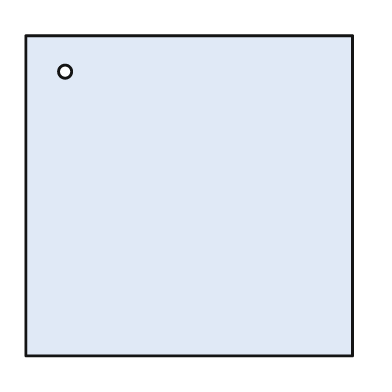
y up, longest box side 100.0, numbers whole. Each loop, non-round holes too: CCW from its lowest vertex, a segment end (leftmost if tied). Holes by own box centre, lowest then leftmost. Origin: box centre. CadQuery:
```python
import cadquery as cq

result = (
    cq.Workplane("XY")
    .moveTo(-50.0, -49.0)
    .lineTo(50.0, -49.0)
    .lineTo(50.0, 49.0)
    .lineTo(-50.0, 49.0)
    .close()
    .moveTo(-38.0, 38.0)
    .circle(2.0)
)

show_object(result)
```